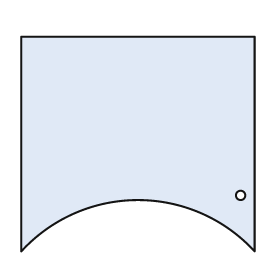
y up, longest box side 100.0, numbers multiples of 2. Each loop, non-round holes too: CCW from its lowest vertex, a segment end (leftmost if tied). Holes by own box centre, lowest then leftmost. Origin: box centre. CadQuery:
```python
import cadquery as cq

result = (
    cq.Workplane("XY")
    .moveTo(-50.0, -46.0)
    .threePointArc((0.0, -24.0), (50.0, -46.0))
    .lineTo(50.0, 46.0)
    .lineTo(-50.0, 46.0)
    .close()
    .moveTo(44.0, -22.0)
    .circle(2.0)
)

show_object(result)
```